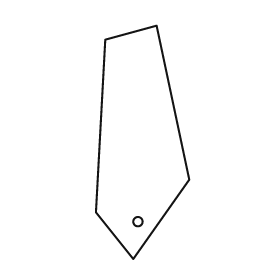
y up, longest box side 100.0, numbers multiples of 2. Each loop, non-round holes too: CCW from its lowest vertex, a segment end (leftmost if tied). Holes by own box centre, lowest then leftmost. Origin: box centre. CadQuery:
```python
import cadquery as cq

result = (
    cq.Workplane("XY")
    .moveTo(-4.0, -50.0)
    .lineTo(20.0, -16.0)
    .lineTo(6.0, 50.0)
    .lineTo(-16.0, 44.0)
    .lineTo(-20.0, -30.0)
    .close()
    .moveTo(-2.0, -34.0)
    .circle(2.0)
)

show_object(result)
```